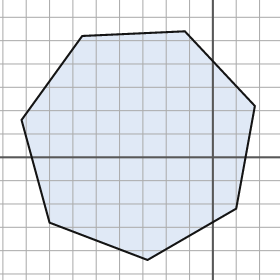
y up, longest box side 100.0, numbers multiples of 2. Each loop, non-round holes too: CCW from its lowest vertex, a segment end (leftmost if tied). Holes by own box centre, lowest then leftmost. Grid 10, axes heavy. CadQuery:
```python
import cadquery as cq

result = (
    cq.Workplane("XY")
    .moveTo(-28.0, -44.0)
    .lineTo(10.0, -22.0)
    .lineTo(18.0, 22.0)
    .lineTo(-12.0, 54.0)
    .lineTo(-56.0, 52.0)
    .lineTo(-82.0, 16.0)
    .lineTo(-70.0, -28.0)
    .close()
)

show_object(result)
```